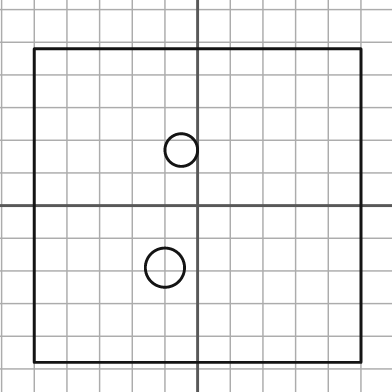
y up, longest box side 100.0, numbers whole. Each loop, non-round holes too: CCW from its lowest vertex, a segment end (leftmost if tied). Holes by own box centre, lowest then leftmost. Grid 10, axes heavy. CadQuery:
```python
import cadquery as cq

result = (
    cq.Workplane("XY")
    .moveTo(-50.0, -48.0)
    .lineTo(50.0, -48.0)
    .lineTo(50.0, 48.0)
    .lineTo(-50.0, 48.0)
    .close()
    .moveTo(-10.0, -19.0)
    .circle(6.0)
    .moveTo(-5.0, 17.0)
    .circle(5.0)
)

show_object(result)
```